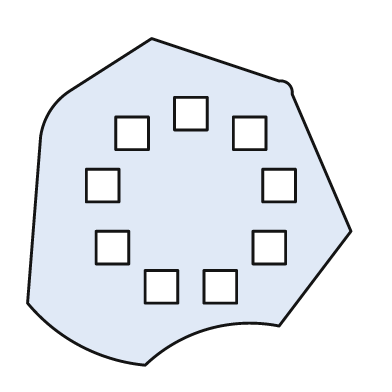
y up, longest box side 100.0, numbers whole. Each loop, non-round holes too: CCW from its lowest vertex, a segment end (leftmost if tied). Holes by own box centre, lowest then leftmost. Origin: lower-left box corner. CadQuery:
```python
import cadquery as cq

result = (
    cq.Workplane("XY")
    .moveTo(36.0, 0.0)
    .threePointArc((55.0, 11.0), (77.0, 12.0))
    .lineTo(99.0, 41.0)
    .lineTo(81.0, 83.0)
    .threePointArc((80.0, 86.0), (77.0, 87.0))
    .lineTo(38.0, 100.0)
    .lineTo(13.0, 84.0)
    .threePointArc((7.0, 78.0), (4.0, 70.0))
    .lineTo(0.0, 19.0)
    .threePointArc((16.0, 6.0), (36.0, 0.0))
    .close()
    .moveTo(36.0, 19.0)
    .lineTo(46.0, 19.0)
    .lineTo(46.0, 29.0)
    .lineTo(36.0, 29.0)
    .close()
    .moveTo(54.0, 19.0)
    .lineTo(64.0, 19.0)
    .lineTo(64.0, 29.0)
    .lineTo(54.0, 29.0)
    .close()
    .moveTo(21.0, 31.0)
    .lineTo(31.0, 31.0)
    .lineTo(31.0, 41.0)
    .lineTo(21.0, 41.0)
    .close()
    .moveTo(69.0, 31.0)
    .lineTo(79.0, 31.0)
    .lineTo(79.0, 41.0)
    .lineTo(69.0, 41.0)
    .close()
    .moveTo(18.0, 50.0)
    .lineTo(28.0, 50.0)
    .lineTo(28.0, 60.0)
    .lineTo(18.0, 60.0)
    .close()
    .moveTo(72.0, 50.0)
    .lineTo(82.0, 50.0)
    .lineTo(82.0, 60.0)
    .lineTo(72.0, 60.0)
    .close()
    .moveTo(27.0, 66.0)
    .lineTo(37.0, 66.0)
    .lineTo(37.0, 76.0)
    .lineTo(27.0, 76.0)
    .close()
    .moveTo(63.0, 66.0)
    .lineTo(73.0, 66.0)
    .lineTo(73.0, 76.0)
    .lineTo(63.0, 76.0)
    .close()
    .moveTo(45.0, 72.0)
    .lineTo(55.0, 72.0)
    .lineTo(55.0, 82.0)
    .lineTo(45.0, 82.0)
    .close()
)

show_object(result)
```